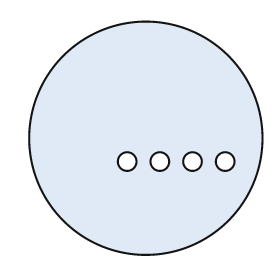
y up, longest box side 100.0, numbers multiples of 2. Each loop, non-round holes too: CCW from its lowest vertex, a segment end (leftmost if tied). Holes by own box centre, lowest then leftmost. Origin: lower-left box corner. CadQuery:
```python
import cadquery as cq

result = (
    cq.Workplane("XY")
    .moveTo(50.0, 50.0)
    .circle(50.0)
    .moveTo(42.0, 40.0)
    .circle(4.0)
    .moveTo(56.0, 40.0)
    .circle(4.0)
    .moveTo(70.0, 40.0)
    .circle(4.0)
    .moveTo(84.0, 40.0)
    .circle(4.0)
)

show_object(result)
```